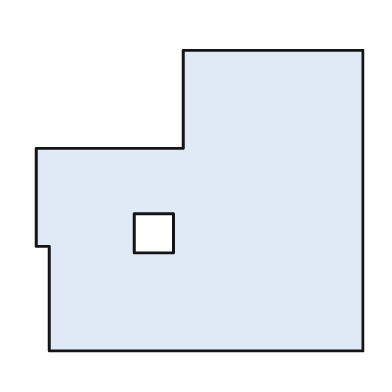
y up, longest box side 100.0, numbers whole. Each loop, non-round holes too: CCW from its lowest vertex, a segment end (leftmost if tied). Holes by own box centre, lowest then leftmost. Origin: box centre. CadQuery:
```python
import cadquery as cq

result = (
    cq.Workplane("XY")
    .moveTo(-46.0, -46.0)
    .lineTo(50.0, -46.0)
    .lineTo(50.0, 46.0)
    .lineTo(-5.0, 46.0)
    .lineTo(-5.0, 16.0)
    .lineTo(-50.0, 16.0)
    .lineTo(-50.0, -14.0)
    .lineTo(-46.0, -14.0)
    .close()
    .moveTo(-20.0, -16.0)
    .lineTo(-8.0, -16.0)
    .lineTo(-8.0, -4.0)
    .lineTo(-20.0, -4.0)
    .close()
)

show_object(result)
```